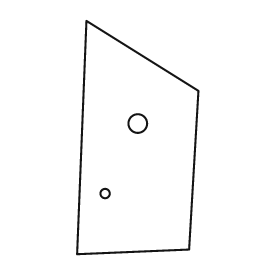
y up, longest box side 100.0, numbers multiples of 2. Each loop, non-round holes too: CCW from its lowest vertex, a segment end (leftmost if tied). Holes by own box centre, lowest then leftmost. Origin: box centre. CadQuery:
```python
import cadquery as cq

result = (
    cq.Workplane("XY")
    .moveTo(-26.0, -50.0)
    .lineTo(22.0, -48.0)
    .lineTo(26.0, 20.0)
    .lineTo(-22.0, 50.0)
    .close()
    .moveTo(-14.0, -24.0)
    .circle(2.0)
    .moveTo(0.0, 6.0)
    .circle(4.0)
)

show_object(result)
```